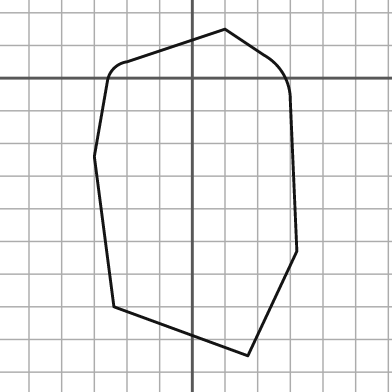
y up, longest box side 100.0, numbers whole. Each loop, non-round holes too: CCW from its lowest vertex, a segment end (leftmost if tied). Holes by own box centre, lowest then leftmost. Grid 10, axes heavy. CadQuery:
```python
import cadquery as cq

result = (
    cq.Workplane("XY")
    .moveTo(17.0, -85.0)
    .lineTo(32.0, -53.0)
    .lineTo(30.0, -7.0)
    .threePointArc((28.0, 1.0), (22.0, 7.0))
    .lineTo(10.0, 15.0)
    .lineTo(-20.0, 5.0)
    .threePointArc((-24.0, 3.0), (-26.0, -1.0))
    .lineTo(-30.0, -24.0)
    .lineTo(-24.0, -70.0)
    .close()
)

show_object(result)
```